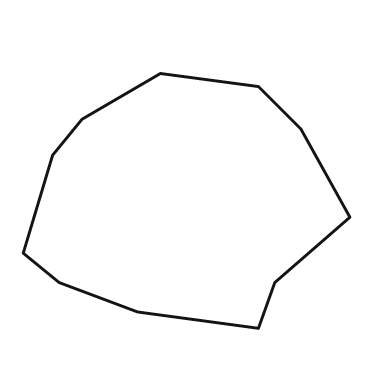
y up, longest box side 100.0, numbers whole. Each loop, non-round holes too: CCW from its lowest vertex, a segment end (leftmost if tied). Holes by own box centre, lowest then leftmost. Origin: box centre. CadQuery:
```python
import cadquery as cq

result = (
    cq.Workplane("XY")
    .moveTo(22.0, -39.0)
    .lineTo(27.0, -25.0)
    .lineTo(50.0, -5.0)
    .lineTo(35.0, 22.0)
    .lineTo(22.0, 35.0)
    .lineTo(-8.0, 39.0)
    .lineTo(-32.0, 25.0)
    .lineTo(-41.0, 14.0)
    .lineTo(-50.0, -16.0)
    .lineTo(-39.0, -25.0)
    .lineTo(-15.0, -34.0)
    .close()
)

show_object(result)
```